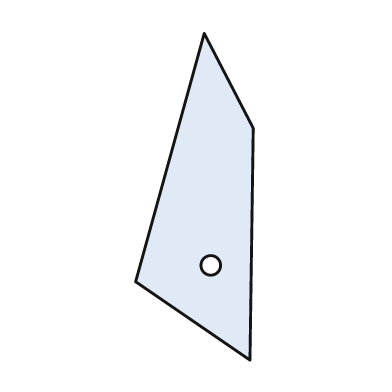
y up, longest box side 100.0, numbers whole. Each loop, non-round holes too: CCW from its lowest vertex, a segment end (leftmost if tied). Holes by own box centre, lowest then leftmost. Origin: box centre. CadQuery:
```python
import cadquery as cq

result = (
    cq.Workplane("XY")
    .moveTo(17.0, -50.0)
    .lineTo(18.0, 21.0)
    .lineTo(3.0, 50.0)
    .lineTo(-18.0, -26.0)
    .close()
    .moveTo(5.0, -21.0)
    .circle(3.0)
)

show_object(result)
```